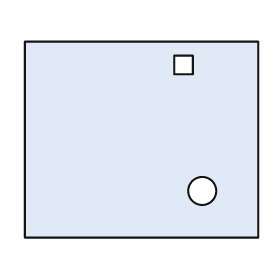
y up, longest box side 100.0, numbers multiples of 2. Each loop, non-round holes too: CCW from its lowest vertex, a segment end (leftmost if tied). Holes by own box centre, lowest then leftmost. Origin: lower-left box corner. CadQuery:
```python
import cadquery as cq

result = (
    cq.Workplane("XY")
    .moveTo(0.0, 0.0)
    .lineTo(100.0, 0.0)
    .lineTo(100.0, 84.0)
    .lineTo(0.0, 84.0)
    .close()
    .moveTo(76.0, 20.0)
    .circle(6.0)
    .moveTo(64.0, 70.0)
    .lineTo(72.0, 70.0)
    .lineTo(72.0, 78.0)
    .lineTo(64.0, 78.0)
    .close()
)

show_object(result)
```